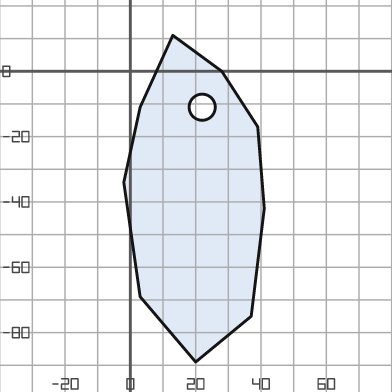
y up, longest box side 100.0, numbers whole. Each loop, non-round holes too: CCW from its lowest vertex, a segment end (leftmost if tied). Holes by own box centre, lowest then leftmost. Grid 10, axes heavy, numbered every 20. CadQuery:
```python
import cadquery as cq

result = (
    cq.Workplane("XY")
    .moveTo(20.0, -89.0)
    .lineTo(37.0, -75.0)
    .lineTo(41.0, -42.0)
    .lineTo(39.0, -17.0)
    .lineTo(28.0, 0.0)
    .lineTo(13.0, 11.0)
    .lineTo(3.0, -11.0)
    .lineTo(-2.0, -34.0)
    .lineTo(3.0, -69.0)
    .close()
    .moveTo(22.0, -11.0)
    .circle(4.0)
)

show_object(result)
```